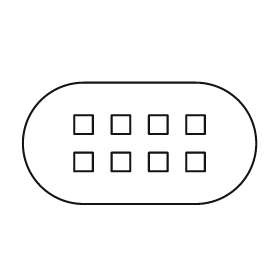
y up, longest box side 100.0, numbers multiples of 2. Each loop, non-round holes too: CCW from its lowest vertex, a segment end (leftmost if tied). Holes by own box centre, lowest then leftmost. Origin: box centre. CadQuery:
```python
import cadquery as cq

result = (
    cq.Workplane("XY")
    .moveTo(-24.0, -26.0)
    .lineTo(24.0, -26.0)
    .threePointArc((50.0, 0.0), (24.0, 26.0))
    .lineTo(-24.0, 26.0)
    .threePointArc((-50.0, 0.0), (-24.0, -26.0))
    .close()
    .moveTo(-28.0, -12.0)
    .lineTo(-20.0, -12.0)
    .lineTo(-20.0, -4.0)
    .lineTo(-28.0, -4.0)
    .close()
    .moveTo(-12.0, -12.0)
    .lineTo(-4.0, -12.0)
    .lineTo(-4.0, -4.0)
    .lineTo(-12.0, -4.0)
    .close()
    .moveTo(4.0, -12.0)
    .lineTo(12.0, -12.0)
    .lineTo(12.0, -4.0)
    .lineTo(4.0, -4.0)
    .close()
    .moveTo(20.0, -12.0)
    .lineTo(28.0, -12.0)
    .lineTo(28.0, -4.0)
    .lineTo(20.0, -4.0)
    .close()
    .moveTo(-28.0, 4.0)
    .lineTo(-20.0, 4.0)
    .lineTo(-20.0, 12.0)
    .lineTo(-28.0, 12.0)
    .close()
    .moveTo(-12.0, 4.0)
    .lineTo(-4.0, 4.0)
    .lineTo(-4.0, 12.0)
    .lineTo(-12.0, 12.0)
    .close()
    .moveTo(4.0, 4.0)
    .lineTo(12.0, 4.0)
    .lineTo(12.0, 12.0)
    .lineTo(4.0, 12.0)
    .close()
    .moveTo(20.0, 4.0)
    .lineTo(28.0, 4.0)
    .lineTo(28.0, 12.0)
    .lineTo(20.0, 12.0)
    .close()
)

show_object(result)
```